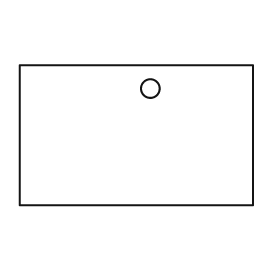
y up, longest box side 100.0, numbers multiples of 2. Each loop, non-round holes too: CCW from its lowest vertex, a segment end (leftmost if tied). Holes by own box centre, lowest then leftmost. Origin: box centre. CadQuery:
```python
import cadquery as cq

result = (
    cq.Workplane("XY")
    .moveTo(-50.0, -30.0)
    .lineTo(50.0, -30.0)
    .lineTo(50.0, 30.0)
    .lineTo(-50.0, 30.0)
    .close()
    .moveTo(6.0, 20.0)
    .circle(4.0)
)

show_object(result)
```